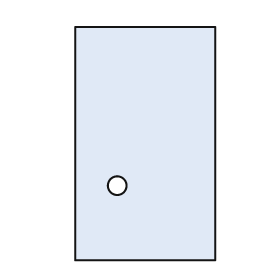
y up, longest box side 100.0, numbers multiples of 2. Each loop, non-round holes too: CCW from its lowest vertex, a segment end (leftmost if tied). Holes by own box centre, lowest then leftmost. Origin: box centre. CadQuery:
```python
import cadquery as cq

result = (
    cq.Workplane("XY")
    .moveTo(-30.0, -50.0)
    .lineTo(30.0, -50.0)
    .lineTo(30.0, 50.0)
    .lineTo(-30.0, 50.0)
    .close()
    .moveTo(-12.0, -18.0)
    .circle(4.0)
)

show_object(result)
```